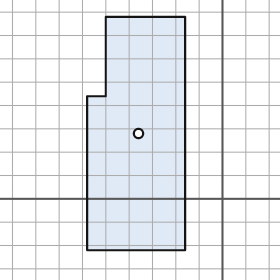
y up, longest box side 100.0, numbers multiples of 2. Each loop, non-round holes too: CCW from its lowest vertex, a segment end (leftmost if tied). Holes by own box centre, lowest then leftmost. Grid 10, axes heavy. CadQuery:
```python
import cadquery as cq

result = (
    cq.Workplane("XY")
    .moveTo(-58.0, -22.0)
    .lineTo(-16.0, -22.0)
    .lineTo(-16.0, 78.0)
    .lineTo(-50.0, 78.0)
    .lineTo(-50.0, 44.0)
    .lineTo(-58.0, 44.0)
    .close()
    .moveTo(-36.0, 28.0)
    .circle(2.0)
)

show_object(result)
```